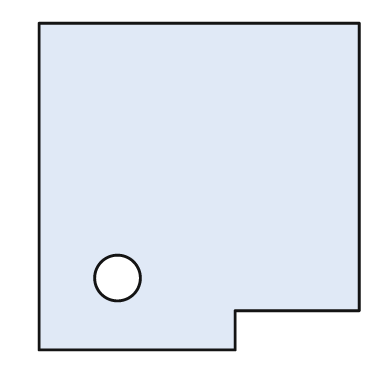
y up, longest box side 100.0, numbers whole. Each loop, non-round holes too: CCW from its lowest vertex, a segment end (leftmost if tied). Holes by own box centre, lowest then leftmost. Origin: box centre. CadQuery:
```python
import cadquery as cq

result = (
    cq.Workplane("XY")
    .moveTo(-49.0, -50.0)
    .lineTo(11.0, -50.0)
    .lineTo(11.0, -38.0)
    .lineTo(49.0, -38.0)
    .lineTo(49.0, 50.0)
    .lineTo(-49.0, 50.0)
    .close()
    .moveTo(-25.0, -28.0)
    .circle(7.0)
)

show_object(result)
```